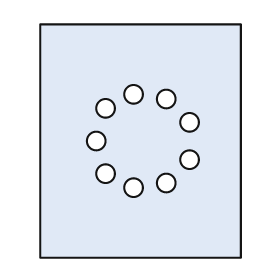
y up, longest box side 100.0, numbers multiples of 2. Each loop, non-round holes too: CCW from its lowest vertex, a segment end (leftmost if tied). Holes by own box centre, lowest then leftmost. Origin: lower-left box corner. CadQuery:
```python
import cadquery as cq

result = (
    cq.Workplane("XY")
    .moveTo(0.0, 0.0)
    .lineTo(86.0, 0.0)
    .lineTo(86.0, 100.0)
    .lineTo(0.0, 100.0)
    .close()
    .moveTo(40.0, 30.0)
    .circle(4.0)
    .moveTo(54.0, 32.0)
    .circle(4.0)
    .moveTo(28.0, 36.0)
    .circle(4.0)
    .moveTo(64.0, 42.0)
    .circle(4.0)
    .moveTo(24.0, 50.0)
    .circle(4.0)
    .moveTo(64.0, 58.0)
    .circle(4.0)
    .moveTo(28.0, 64.0)
    .circle(4.0)
    .moveTo(54.0, 68.0)
    .circle(4.0)
    .moveTo(40.0, 70.0)
    .circle(4.0)
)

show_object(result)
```